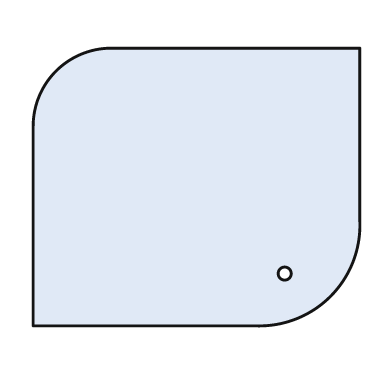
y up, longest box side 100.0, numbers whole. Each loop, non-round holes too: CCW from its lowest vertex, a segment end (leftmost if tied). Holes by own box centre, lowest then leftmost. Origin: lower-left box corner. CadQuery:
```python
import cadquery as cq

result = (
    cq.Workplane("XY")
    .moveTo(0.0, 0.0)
    .lineTo(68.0, 0.0)
    .threePointArc((91.0, 9.0), (100.0, 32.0))
    .lineTo(100.0, 85.0)
    .lineTo(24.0, 85.0)
    .threePointArc((7.0, 78.0), (0.0, 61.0))
    .close()
    .moveTo(77.0, 16.0)
    .circle(2.0)
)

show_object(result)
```